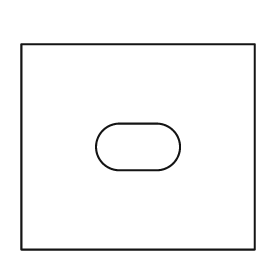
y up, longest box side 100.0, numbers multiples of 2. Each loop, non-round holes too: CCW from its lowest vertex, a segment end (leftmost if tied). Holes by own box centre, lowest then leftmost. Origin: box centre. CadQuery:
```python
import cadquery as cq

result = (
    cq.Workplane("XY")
    .moveTo(-50.0, -44.0)
    .lineTo(50.0, -44.0)
    .lineTo(50.0, 44.0)
    .lineTo(-50.0, 44.0)
    .close()
    .moveTo(-8.0, -10.0)
    .lineTo(8.0, -10.0)
    .threePointArc((18.0, 0.0), (8.0, 10.0))
    .lineTo(-8.0, 10.0)
    .threePointArc((-18.0, 0.0), (-8.0, -10.0))
    .close()
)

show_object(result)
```